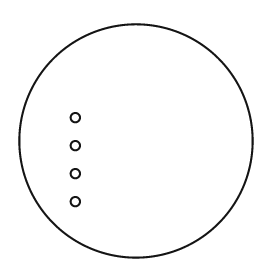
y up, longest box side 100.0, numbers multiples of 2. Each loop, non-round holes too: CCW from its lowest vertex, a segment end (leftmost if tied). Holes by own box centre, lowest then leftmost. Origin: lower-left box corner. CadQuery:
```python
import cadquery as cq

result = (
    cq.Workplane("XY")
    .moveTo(50.0, 50.0)
    .circle(50.0)
    .moveTo(24.0, 24.0)
    .circle(2.0)
    .moveTo(24.0, 36.0)
    .circle(2.0)
    .moveTo(24.0, 48.0)
    .circle(2.0)
    .moveTo(24.0, 60.0)
    .circle(2.0)
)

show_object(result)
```